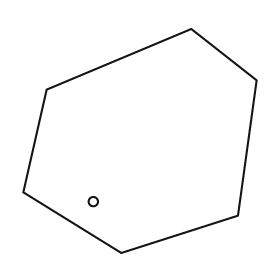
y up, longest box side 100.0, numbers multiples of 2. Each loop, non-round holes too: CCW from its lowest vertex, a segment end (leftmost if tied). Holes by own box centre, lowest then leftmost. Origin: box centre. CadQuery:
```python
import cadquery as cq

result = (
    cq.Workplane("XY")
    .moveTo(-8.0, -48.0)
    .lineTo(42.0, -32.0)
    .lineTo(50.0, 26.0)
    .lineTo(22.0, 48.0)
    .lineTo(-40.0, 22.0)
    .lineTo(-50.0, -22.0)
    .close()
    .moveTo(-20.0, -26.0)
    .circle(2.0)
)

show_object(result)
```